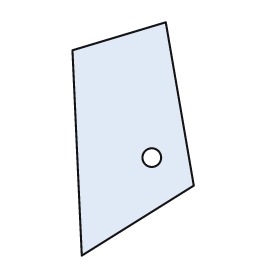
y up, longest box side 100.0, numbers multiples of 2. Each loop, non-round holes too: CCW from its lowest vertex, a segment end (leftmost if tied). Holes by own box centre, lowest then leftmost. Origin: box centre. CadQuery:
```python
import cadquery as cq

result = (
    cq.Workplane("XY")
    .moveTo(-22.0, -50.0)
    .lineTo(26.0, -20.0)
    .lineTo(14.0, 50.0)
    .lineTo(-26.0, 38.0)
    .close()
    .moveTo(8.0, -8.0)
    .circle(4.0)
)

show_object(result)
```